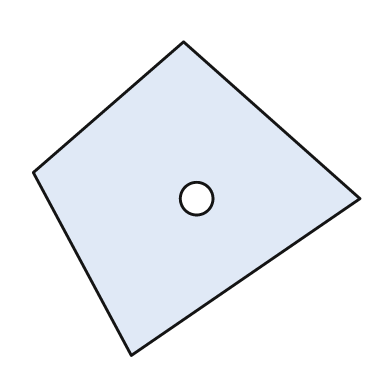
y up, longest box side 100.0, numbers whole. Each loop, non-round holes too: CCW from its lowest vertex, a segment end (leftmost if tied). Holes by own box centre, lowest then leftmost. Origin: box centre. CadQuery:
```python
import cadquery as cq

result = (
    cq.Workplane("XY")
    .moveTo(-20.0, -48.0)
    .lineTo(50.0, 0.0)
    .lineTo(-4.0, 48.0)
    .lineTo(-50.0, 8.0)
    .close()
    .moveTo(0.0, 0.0)
    .circle(5.0)
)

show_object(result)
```